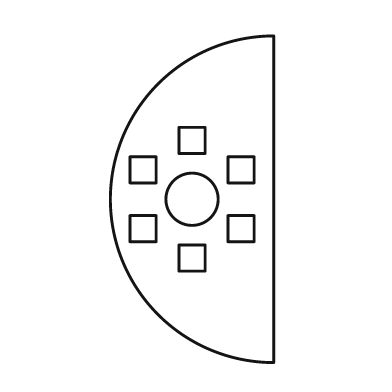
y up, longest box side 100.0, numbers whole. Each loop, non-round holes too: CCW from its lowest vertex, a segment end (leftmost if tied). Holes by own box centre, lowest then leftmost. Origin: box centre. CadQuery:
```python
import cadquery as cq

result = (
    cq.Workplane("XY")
    .moveTo(25.0, -50.0)
    .lineTo(25.0, 50.0)
    .threePointArc((-25.0, 0.0), (25.0, -50.0))
    .close()
    .moveTo(-4.0, -22.0)
    .lineTo(4.0, -22.0)
    .lineTo(4.0, -14.0)
    .lineTo(-4.0, -14.0)
    .close()
    .moveTo(-19.0, -13.0)
    .lineTo(-11.0, -13.0)
    .lineTo(-11.0, -5.0)
    .lineTo(-19.0, -5.0)
    .close()
    .moveTo(11.0, -13.0)
    .lineTo(19.0, -13.0)
    .lineTo(19.0, -5.0)
    .lineTo(11.0, -5.0)
    .close()
    .moveTo(0.0, 0.0)
    .circle(8.0)
    .moveTo(-19.0, 5.0)
    .lineTo(-11.0, 5.0)
    .lineTo(-11.0, 13.0)
    .lineTo(-19.0, 13.0)
    .close()
    .moveTo(11.0, 5.0)
    .lineTo(19.0, 5.0)
    .lineTo(19.0, 13.0)
    .lineTo(11.0, 13.0)
    .close()
    .moveTo(-4.0, 14.0)
    .lineTo(4.0, 14.0)
    .lineTo(4.0, 22.0)
    .lineTo(-4.0, 22.0)
    .close()
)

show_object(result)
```